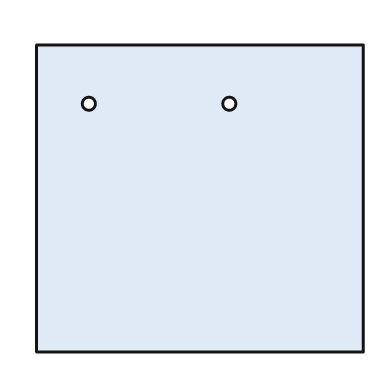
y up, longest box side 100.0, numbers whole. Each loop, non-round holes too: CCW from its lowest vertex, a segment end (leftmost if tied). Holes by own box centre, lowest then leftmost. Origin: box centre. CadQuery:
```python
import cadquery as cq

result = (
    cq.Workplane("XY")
    .moveTo(-50.0, -47.0)
    .lineTo(50.0, -47.0)
    .lineTo(50.0, 47.0)
    .lineTo(-50.0, 47.0)
    .close()
    .moveTo(-34.0, 29.0)
    .circle(2.0)
    .moveTo(9.0, 29.0)
    .circle(2.0)
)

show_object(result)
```